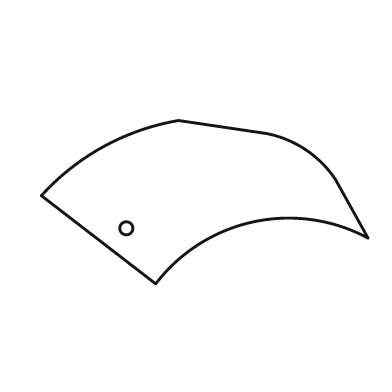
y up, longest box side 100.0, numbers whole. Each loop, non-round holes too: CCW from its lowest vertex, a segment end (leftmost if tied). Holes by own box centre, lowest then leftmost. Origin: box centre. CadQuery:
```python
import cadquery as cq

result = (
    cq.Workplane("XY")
    .moveTo(-15.0, -25.0)
    .threePointArc((15.0, -6.0), (50.0, -11.0))
    .lineTo(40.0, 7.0)
    .threePointArc((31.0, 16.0), (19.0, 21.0))
    .lineTo(-8.0, 25.0)
    .threePointArc((-31.0, 17.0), (-50.0, 2.0))
    .close()
    .moveTo(-24.0, -8.0)
    .circle(2.0)
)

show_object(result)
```